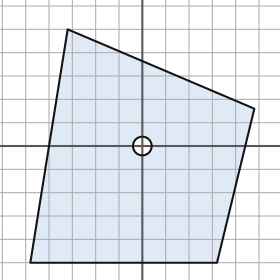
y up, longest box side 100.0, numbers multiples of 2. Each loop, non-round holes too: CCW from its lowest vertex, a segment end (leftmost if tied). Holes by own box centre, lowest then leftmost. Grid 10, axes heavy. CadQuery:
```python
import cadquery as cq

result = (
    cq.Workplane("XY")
    .moveTo(-48.0, -50.0)
    .lineTo(32.0, -50.0)
    .lineTo(48.0, 16.0)
    .lineTo(-32.0, 50.0)
    .close()
    .moveTo(0.0, 0.0)
    .circle(4.0)
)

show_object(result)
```